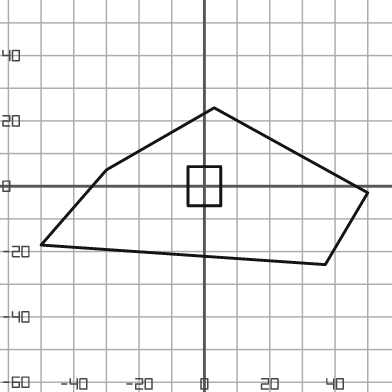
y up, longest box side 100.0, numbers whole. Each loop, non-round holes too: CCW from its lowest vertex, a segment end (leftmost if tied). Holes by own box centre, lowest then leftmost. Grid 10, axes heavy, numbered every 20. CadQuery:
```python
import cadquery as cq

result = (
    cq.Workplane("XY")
    .moveTo(37.0, -24.0)
    .lineTo(50.0, -2.0)
    .lineTo(3.0, 24.0)
    .lineTo(-30.0, 5.0)
    .lineTo(-50.0, -18.0)
    .close()
    .moveTo(-5.0, -6.0)
    .lineTo(5.0, -6.0)
    .lineTo(5.0, 6.0)
    .lineTo(-5.0, 6.0)
    .close()
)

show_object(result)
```